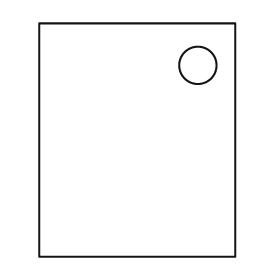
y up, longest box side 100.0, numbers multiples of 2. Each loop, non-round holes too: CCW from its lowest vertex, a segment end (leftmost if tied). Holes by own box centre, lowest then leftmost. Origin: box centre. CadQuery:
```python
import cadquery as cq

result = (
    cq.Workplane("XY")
    .moveTo(-42.0, -50.0)
    .lineTo(42.0, -50.0)
    .lineTo(42.0, 50.0)
    .lineTo(-42.0, 50.0)
    .close()
    .moveTo(26.0, 32.0)
    .circle(8.0)
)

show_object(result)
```